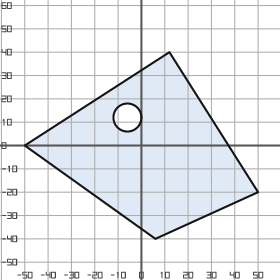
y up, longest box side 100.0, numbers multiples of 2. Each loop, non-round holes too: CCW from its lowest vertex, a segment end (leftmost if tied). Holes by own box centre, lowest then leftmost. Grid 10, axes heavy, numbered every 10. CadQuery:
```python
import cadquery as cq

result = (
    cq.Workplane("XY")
    .moveTo(6.0, -40.0)
    .lineTo(50.0, -20.0)
    .lineTo(12.0, 40.0)
    .lineTo(-50.0, 0.0)
    .close()
    .moveTo(-6.0, 12.0)
    .circle(6.0)
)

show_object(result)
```